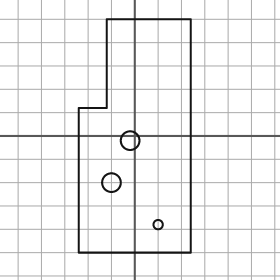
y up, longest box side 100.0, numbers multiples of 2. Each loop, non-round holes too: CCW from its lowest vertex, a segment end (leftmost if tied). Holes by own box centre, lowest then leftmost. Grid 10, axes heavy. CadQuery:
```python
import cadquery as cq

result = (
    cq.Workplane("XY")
    .moveTo(-24.0, -50.0)
    .lineTo(24.0, -50.0)
    .lineTo(24.0, 50.0)
    .lineTo(-12.0, 50.0)
    .lineTo(-12.0, 12.0)
    .lineTo(-24.0, 12.0)
    .close()
    .moveTo(10.0, -38.0)
    .circle(2.0)
    .moveTo(-10.0, -20.0)
    .circle(4.0)
    .moveTo(-2.0, -2.0)
    .circle(4.0)
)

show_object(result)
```